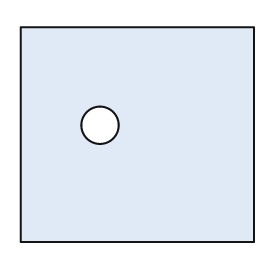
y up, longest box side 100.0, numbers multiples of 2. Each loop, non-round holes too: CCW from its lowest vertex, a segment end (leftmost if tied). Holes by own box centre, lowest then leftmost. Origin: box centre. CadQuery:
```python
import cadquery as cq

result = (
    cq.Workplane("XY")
    .moveTo(-50.0, -46.0)
    .lineTo(50.0, -46.0)
    .lineTo(50.0, 46.0)
    .lineTo(-50.0, 46.0)
    .close()
    .moveTo(-16.0, 4.0)
    .circle(8.0)
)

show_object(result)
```